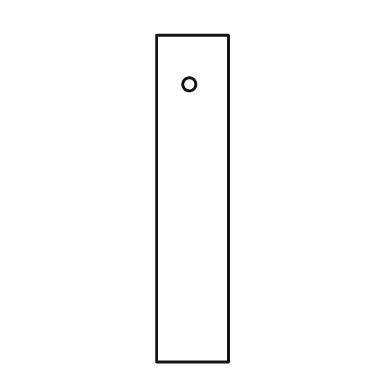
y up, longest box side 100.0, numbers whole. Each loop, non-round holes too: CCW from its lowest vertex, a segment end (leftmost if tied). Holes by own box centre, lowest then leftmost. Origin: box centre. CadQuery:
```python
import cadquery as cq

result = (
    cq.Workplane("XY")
    .moveTo(-11.0, -50.0)
    .lineTo(11.0, -50.0)
    .lineTo(11.0, 50.0)
    .lineTo(-11.0, 50.0)
    .close()
    .moveTo(-1.0, 35.0)
    .circle(2.0)
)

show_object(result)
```